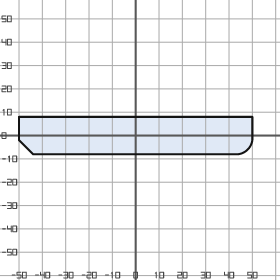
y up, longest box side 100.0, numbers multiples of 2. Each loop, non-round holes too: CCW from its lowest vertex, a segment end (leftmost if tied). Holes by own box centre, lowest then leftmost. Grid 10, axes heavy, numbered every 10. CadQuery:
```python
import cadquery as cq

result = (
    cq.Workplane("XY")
    .moveTo(-44.0, -8.0)
    .lineTo(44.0, -8.0)
    .threePointArc((48.0, -6.0), (50.0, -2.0))
    .lineTo(50.0, 8.0)
    .lineTo(-50.0, 8.0)
    .lineTo(-50.0, -2.0)
    .close()
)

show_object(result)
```